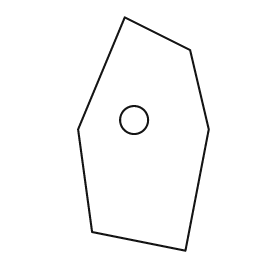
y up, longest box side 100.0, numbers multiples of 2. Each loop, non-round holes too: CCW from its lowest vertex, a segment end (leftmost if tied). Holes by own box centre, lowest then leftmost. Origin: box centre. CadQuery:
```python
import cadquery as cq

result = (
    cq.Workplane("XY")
    .moveTo(18.0, -50.0)
    .lineTo(28.0, 2.0)
    .lineTo(20.0, 36.0)
    .lineTo(-8.0, 50.0)
    .lineTo(-28.0, 2.0)
    .lineTo(-22.0, -42.0)
    .close()
    .moveTo(-4.0, 6.0)
    .circle(6.0)
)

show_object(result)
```